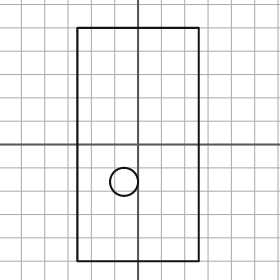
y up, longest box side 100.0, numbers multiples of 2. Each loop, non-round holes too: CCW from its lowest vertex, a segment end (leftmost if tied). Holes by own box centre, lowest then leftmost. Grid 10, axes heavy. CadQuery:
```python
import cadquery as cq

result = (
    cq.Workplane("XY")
    .moveTo(-26.0, -50.0)
    .lineTo(26.0, -50.0)
    .lineTo(26.0, 50.0)
    .lineTo(-26.0, 50.0)
    .close()
    .moveTo(-6.0, -16.0)
    .circle(6.0)
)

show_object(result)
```